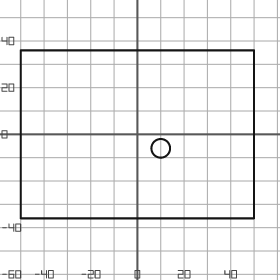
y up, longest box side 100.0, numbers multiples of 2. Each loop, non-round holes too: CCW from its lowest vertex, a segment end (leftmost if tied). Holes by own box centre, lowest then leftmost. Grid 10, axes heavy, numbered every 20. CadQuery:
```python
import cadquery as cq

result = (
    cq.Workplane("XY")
    .moveTo(-50.0, -36.0)
    .lineTo(50.0, -36.0)
    .lineTo(50.0, 36.0)
    .lineTo(-50.0, 36.0)
    .close()
    .moveTo(10.0, -6.0)
    .circle(4.0)
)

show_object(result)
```